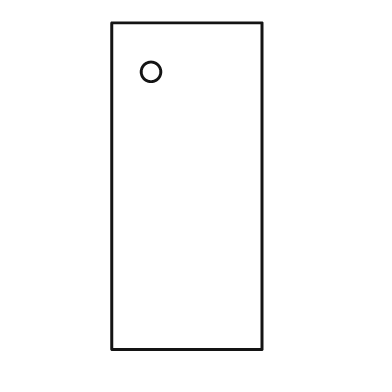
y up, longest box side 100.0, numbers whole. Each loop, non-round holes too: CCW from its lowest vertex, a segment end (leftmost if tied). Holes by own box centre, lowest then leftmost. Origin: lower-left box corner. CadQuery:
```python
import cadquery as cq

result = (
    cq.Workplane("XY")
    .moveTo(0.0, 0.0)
    .lineTo(46.0, 0.0)
    .lineTo(46.0, 100.0)
    .lineTo(0.0, 100.0)
    .close()
    .moveTo(12.0, 85.0)
    .circle(3.0)
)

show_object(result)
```